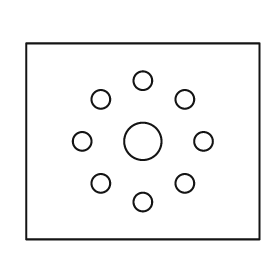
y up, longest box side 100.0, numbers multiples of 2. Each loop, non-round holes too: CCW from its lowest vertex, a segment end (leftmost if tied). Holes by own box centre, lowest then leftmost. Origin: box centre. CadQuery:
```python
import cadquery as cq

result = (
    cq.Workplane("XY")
    .moveTo(-50.0, -42.0)
    .lineTo(50.0, -42.0)
    .lineTo(50.0, 42.0)
    .lineTo(-50.0, 42.0)
    .close()
    .moveTo(0.0, -26.0)
    .circle(4.0)
    .moveTo(-18.0, -18.0)
    .circle(4.0)
    .moveTo(18.0, -18.0)
    .circle(4.0)
    .moveTo(-26.0, 0.0)
    .circle(4.0)
    .moveTo(0.0, 0.0)
    .circle(8.0)
    .moveTo(26.0, 0.0)
    .circle(4.0)
    .moveTo(-18.0, 18.0)
    .circle(4.0)
    .moveTo(18.0, 18.0)
    .circle(4.0)
    .moveTo(0.0, 26.0)
    .circle(4.0)
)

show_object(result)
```